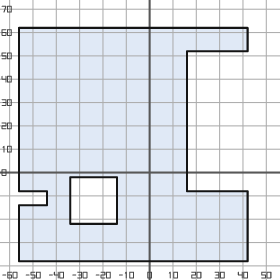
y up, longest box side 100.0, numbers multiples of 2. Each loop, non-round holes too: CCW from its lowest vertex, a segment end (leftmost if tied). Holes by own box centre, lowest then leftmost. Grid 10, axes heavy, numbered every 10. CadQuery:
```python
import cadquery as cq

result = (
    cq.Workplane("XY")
    .moveTo(-56.0, -38.0)
    .lineTo(42.0, -38.0)
    .lineTo(42.0, -8.0)
    .lineTo(16.0, -8.0)
    .lineTo(16.0, 52.0)
    .lineTo(42.0, 52.0)
    .lineTo(42.0, 62.0)
    .lineTo(-56.0, 62.0)
    .lineTo(-56.0, -8.0)
    .lineTo(-44.0, -8.0)
    .lineTo(-44.0, -14.0)
    .lineTo(-56.0, -14.0)
    .close()
    .moveTo(-34.0, -22.0)
    .lineTo(-14.0, -22.0)
    .lineTo(-14.0, -2.0)
    .lineTo(-34.0, -2.0)
    .close()
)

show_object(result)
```